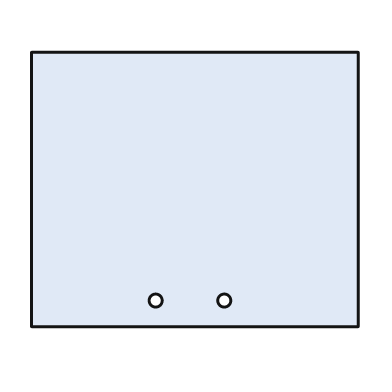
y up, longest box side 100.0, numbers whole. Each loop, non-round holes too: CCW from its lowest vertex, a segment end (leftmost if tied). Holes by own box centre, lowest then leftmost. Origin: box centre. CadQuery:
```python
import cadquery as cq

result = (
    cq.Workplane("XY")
    .moveTo(-50.0, -42.0)
    .lineTo(50.0, -42.0)
    .lineTo(50.0, 42.0)
    .lineTo(-50.0, 42.0)
    .close()
    .moveTo(-12.0, -34.0)
    .circle(2.0)
    .moveTo(9.0, -34.0)
    .circle(2.0)
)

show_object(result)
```